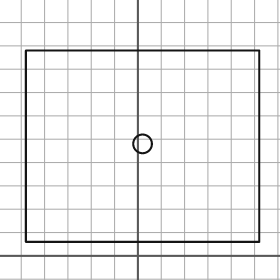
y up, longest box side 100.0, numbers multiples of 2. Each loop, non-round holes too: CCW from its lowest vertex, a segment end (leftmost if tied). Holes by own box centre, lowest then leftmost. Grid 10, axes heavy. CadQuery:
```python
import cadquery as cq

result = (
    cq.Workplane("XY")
    .moveTo(-48.0, 6.0)
    .lineTo(52.0, 6.0)
    .lineTo(52.0, 88.0)
    .lineTo(-48.0, 88.0)
    .close()
    .moveTo(2.0, 48.0)
    .circle(4.0)
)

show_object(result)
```